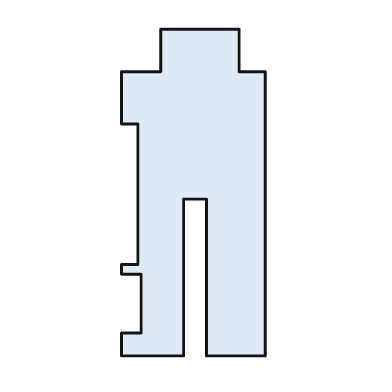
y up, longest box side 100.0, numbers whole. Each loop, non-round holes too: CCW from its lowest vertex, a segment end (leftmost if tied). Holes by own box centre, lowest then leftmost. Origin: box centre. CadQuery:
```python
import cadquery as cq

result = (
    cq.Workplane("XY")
    .moveTo(-22.0, -50.0)
    .lineTo(-3.0, -50.0)
    .lineTo(-3.0, -2.0)
    .lineTo(4.0, -2.0)
    .lineTo(4.0, -50.0)
    .lineTo(22.0, -50.0)
    .lineTo(22.0, 37.0)
    .lineTo(14.0, 37.0)
    .lineTo(14.0, 50.0)
    .lineTo(-10.0, 50.0)
    .lineTo(-10.0, 37.0)
    .lineTo(-22.0, 37.0)
    .lineTo(-22.0, 21.0)
    .lineTo(-17.0, 21.0)
    .lineTo(-17.0, -22.0)
    .lineTo(-22.0, -22.0)
    .lineTo(-22.0, -25.0)
    .lineTo(-16.0, -25.0)
    .lineTo(-16.0, -43.0)
    .lineTo(-22.0, -43.0)
    .close()
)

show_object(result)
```